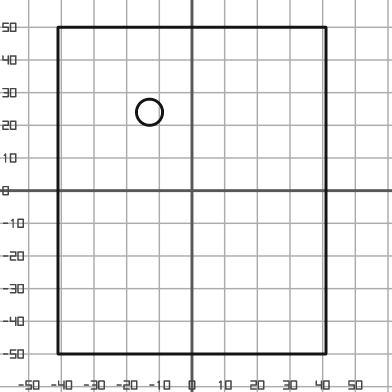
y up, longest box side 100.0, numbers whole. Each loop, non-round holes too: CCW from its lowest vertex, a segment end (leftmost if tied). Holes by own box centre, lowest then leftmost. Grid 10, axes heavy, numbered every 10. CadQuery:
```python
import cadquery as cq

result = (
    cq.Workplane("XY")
    .moveTo(-41.0, -50.0)
    .lineTo(41.0, -50.0)
    .lineTo(41.0, 50.0)
    .lineTo(-41.0, 50.0)
    .close()
    .moveTo(-13.0, 24.0)
    .circle(4.0)
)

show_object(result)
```